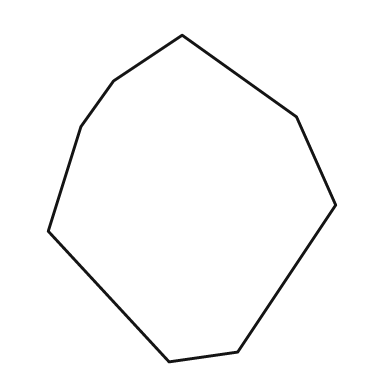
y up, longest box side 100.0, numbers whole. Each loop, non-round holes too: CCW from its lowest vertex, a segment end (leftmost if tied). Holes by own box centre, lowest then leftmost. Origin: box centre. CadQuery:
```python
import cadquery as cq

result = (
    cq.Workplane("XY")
    .moveTo(-7.0, -50.0)
    .lineTo(14.0, -47.0)
    .lineTo(44.0, -2.0)
    .lineTo(32.0, 25.0)
    .lineTo(-3.0, 50.0)
    .lineTo(-24.0, 36.0)
    .lineTo(-34.0, 22.0)
    .lineTo(-44.0, -10.0)
    .close()
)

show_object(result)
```